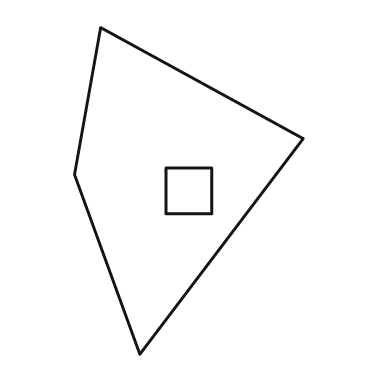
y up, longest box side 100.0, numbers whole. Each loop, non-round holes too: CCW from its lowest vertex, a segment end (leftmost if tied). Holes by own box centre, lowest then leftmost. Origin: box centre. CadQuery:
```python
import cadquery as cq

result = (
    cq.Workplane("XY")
    .moveTo(-15.0, -50.0)
    .lineTo(35.0, 16.0)
    .lineTo(-27.0, 50.0)
    .lineTo(-35.0, 5.0)
    .close()
    .moveTo(-7.0, -7.0)
    .lineTo(7.0, -7.0)
    .lineTo(7.0, 7.0)
    .lineTo(-7.0, 7.0)
    .close()
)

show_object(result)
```